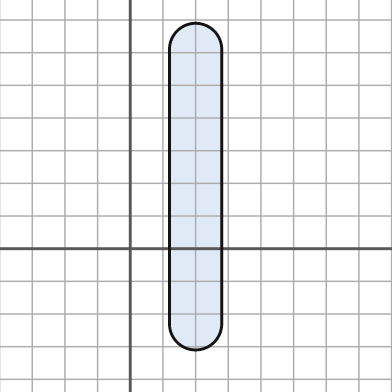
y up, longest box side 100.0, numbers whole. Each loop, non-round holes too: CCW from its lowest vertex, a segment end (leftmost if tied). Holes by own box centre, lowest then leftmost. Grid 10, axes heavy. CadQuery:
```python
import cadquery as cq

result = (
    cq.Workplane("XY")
    .moveTo(12.0, -23.0)
    .threePointArc((20.0, -31.0), (28.0, -23.0))
    .lineTo(28.0, 61.0)
    .threePointArc((20.0, 69.0), (12.0, 61.0))
    .close()
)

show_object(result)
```